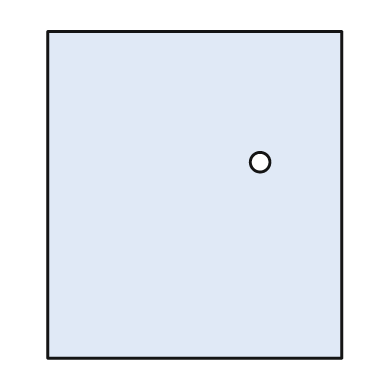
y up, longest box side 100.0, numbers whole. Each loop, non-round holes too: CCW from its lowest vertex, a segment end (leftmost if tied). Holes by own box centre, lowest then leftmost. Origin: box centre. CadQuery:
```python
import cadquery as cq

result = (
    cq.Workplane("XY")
    .moveTo(-45.0, -50.0)
    .lineTo(45.0, -50.0)
    .lineTo(45.0, 50.0)
    .lineTo(-45.0, 50.0)
    .close()
    .moveTo(20.0, 10.0)
    .circle(3.0)
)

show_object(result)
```